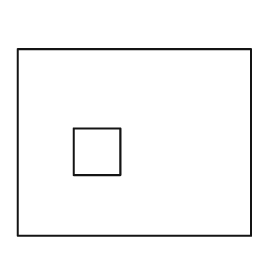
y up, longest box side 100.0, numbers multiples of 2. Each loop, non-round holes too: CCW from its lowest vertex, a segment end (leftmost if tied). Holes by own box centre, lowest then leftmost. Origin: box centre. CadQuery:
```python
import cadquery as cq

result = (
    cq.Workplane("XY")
    .moveTo(-50.0, -40.0)
    .lineTo(50.0, -40.0)
    .lineTo(50.0, 40.0)
    .lineTo(-50.0, 40.0)
    .close()
    .moveTo(-26.0, -14.0)
    .lineTo(-6.0, -14.0)
    .lineTo(-6.0, 6.0)
    .lineTo(-26.0, 6.0)
    .close()
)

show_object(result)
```